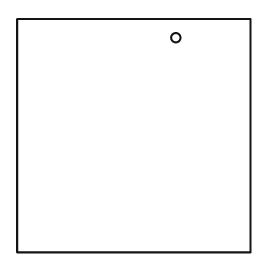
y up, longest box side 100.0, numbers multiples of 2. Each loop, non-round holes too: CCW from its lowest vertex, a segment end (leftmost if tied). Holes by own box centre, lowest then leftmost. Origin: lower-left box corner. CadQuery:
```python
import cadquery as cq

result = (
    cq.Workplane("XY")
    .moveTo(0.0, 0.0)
    .lineTo(100.0, 0.0)
    .lineTo(100.0, 100.0)
    .lineTo(0.0, 100.0)
    .close()
    .moveTo(68.0, 92.0)
    .circle(2.0)
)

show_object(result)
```